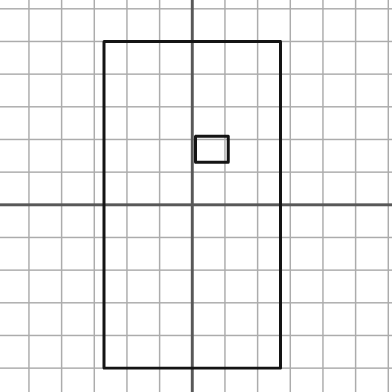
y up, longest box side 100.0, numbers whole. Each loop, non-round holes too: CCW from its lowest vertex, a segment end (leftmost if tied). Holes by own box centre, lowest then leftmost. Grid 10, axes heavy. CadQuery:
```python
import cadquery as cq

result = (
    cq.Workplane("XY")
    .moveTo(-27.0, -50.0)
    .lineTo(27.0, -50.0)
    .lineTo(27.0, 50.0)
    .lineTo(-27.0, 50.0)
    .close()
    .moveTo(1.0, 13.0)
    .lineTo(11.0, 13.0)
    .lineTo(11.0, 21.0)
    .lineTo(1.0, 21.0)
    .close()
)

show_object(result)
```